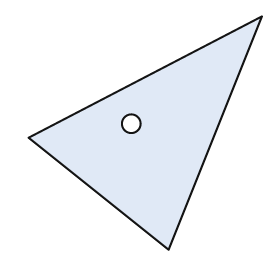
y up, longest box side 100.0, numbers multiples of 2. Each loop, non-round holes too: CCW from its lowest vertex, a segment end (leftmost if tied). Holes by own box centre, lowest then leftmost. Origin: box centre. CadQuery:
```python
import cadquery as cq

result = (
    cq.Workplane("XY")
    .moveTo(10.0, -50.0)
    .lineTo(50.0, 50.0)
    .lineTo(-50.0, -2.0)
    .close()
    .moveTo(-6.0, 4.0)
    .circle(4.0)
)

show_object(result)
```